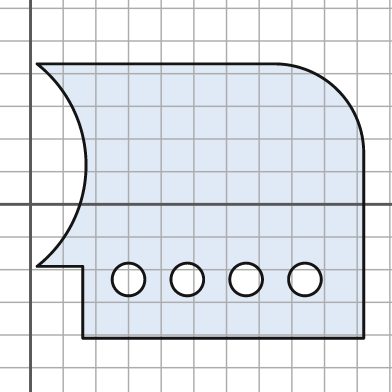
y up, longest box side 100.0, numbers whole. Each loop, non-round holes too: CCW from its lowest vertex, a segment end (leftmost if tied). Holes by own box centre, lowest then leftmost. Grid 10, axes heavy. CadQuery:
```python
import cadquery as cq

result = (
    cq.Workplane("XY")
    .moveTo(16.0, -41.0)
    .lineTo(102.0, -41.0)
    .lineTo(102.0, 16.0)
    .threePointArc((94.0, 35.0), (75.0, 43.0))
    .lineTo(2.0, 43.0)
    .threePointArc((17.0, 12.0), (2.0, -19.0))
    .lineTo(16.0, -19.0)
    .close()
    .moveTo(30.0, -23.0)
    .circle(5.0)
    .moveTo(48.0, -23.0)
    .circle(5.0)
    .moveTo(66.0, -23.0)
    .circle(5.0)
    .moveTo(84.0, -23.0)
    .circle(5.0)
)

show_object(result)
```